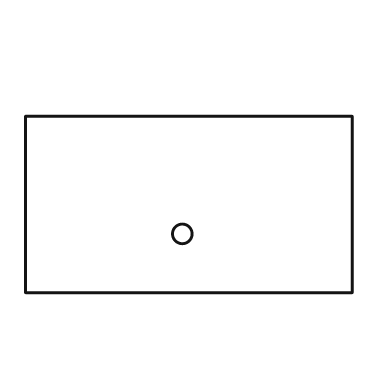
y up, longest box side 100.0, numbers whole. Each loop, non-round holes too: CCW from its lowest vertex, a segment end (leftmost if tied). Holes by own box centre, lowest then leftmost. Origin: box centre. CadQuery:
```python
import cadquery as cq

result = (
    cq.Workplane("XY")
    .moveTo(-50.0, -27.0)
    .lineTo(50.0, -27.0)
    .lineTo(50.0, 27.0)
    .lineTo(-50.0, 27.0)
    .close()
    .moveTo(-2.0, -9.0)
    .circle(3.0)
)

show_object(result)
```